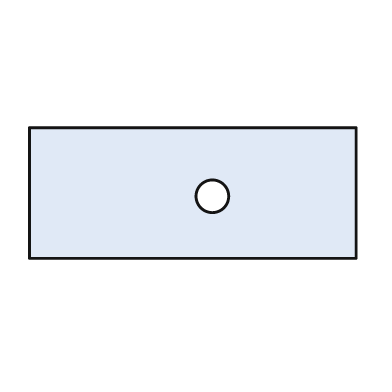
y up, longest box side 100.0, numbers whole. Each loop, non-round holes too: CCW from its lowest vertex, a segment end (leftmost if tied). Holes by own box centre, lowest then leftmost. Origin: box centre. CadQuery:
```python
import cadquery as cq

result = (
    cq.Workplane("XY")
    .moveTo(-50.0, -20.0)
    .lineTo(50.0, -20.0)
    .lineTo(50.0, 20.0)
    .lineTo(-50.0, 20.0)
    .close()
    .moveTo(6.0, -1.0)
    .circle(5.0)
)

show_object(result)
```